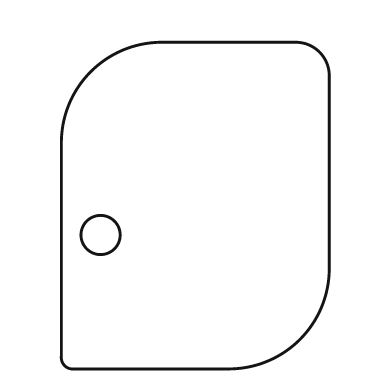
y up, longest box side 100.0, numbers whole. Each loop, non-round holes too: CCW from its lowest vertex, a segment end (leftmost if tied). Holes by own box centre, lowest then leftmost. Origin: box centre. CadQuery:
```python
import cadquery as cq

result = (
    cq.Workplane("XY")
    .moveTo(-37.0, -50.0)
    .lineTo(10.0, -50.0)
    .threePointArc((32.0, -41.0), (41.0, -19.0))
    .lineTo(41.0, 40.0)
    .threePointArc((38.0, 47.0), (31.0, 50.0))
    .lineTo(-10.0, 50.0)
    .threePointArc((-32.0, 41.0), (-41.0, 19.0))
    .lineTo(-41.0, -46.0)
    .threePointArc((-40.0, -49.0), (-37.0, -50.0))
    .close()
    .moveTo(-29.0, -9.0)
    .circle(6.0)
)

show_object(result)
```